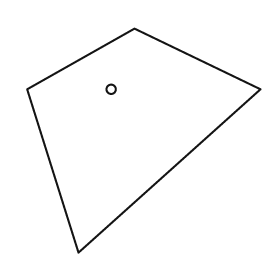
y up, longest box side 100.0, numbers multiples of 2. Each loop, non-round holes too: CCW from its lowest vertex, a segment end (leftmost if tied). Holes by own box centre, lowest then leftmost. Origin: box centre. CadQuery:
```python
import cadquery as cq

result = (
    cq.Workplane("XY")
    .moveTo(-28.0, -48.0)
    .lineTo(50.0, 22.0)
    .lineTo(-4.0, 48.0)
    .lineTo(-50.0, 22.0)
    .close()
    .moveTo(-14.0, 22.0)
    .circle(2.0)
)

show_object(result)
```